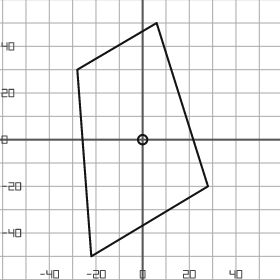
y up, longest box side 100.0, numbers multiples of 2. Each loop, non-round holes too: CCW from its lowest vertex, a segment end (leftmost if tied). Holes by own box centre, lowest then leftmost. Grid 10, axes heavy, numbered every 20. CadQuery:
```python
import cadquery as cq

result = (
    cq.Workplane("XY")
    .moveTo(-22.0, -50.0)
    .lineTo(28.0, -20.0)
    .lineTo(6.0, 50.0)
    .lineTo(-28.0, 30.0)
    .close()
    .moveTo(0.0, 0.0)
    .circle(2.0)
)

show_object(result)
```